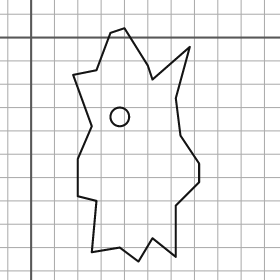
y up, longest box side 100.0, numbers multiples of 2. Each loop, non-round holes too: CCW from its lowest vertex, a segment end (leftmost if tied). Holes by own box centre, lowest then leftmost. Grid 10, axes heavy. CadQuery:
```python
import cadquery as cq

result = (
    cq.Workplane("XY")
    .moveTo(46.0, -96.0)
    .lineTo(52.0, -86.0)
    .lineTo(62.0, -94.0)
    .lineTo(62.0, -72.0)
    .lineTo(72.0, -62.0)
    .lineTo(72.0, -54.0)
    .lineTo(64.0, -42.0)
    .lineTo(62.0, -26.0)
    .lineTo(68.0, -4.0)
    .lineTo(52.0, -18.0)
    .lineTo(50.0, -12.0)
    .lineTo(40.0, 4.0)
    .lineTo(34.0, 2.0)
    .lineTo(28.0, -14.0)
    .lineTo(18.0, -16.0)
    .lineTo(26.0, -38.0)
    .lineTo(20.0, -52.0)
    .lineTo(20.0, -68.0)
    .lineTo(28.0, -70.0)
    .lineTo(26.0, -92.0)
    .lineTo(38.0, -90.0)
    .close()
    .moveTo(38.0, -34.0)
    .circle(4.0)
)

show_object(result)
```